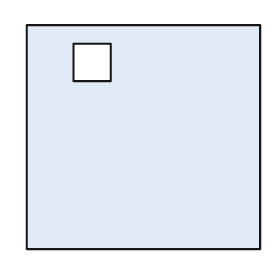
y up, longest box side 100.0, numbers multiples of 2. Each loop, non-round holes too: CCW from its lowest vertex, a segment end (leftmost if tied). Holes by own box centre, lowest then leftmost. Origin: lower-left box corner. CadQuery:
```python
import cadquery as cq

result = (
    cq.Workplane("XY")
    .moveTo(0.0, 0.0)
    .lineTo(100.0, 0.0)
    .lineTo(100.0, 96.0)
    .lineTo(0.0, 96.0)
    .close()
    .moveTo(20.0, 72.0)
    .lineTo(36.0, 72.0)
    .lineTo(36.0, 88.0)
    .lineTo(20.0, 88.0)
    .close()
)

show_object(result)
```